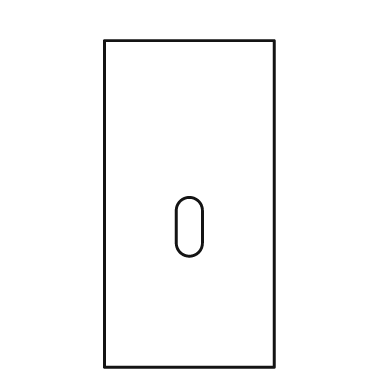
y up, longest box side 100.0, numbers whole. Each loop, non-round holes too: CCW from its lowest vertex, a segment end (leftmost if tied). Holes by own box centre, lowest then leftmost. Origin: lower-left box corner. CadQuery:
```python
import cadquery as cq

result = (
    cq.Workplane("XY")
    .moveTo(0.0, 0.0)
    .lineTo(52.0, 0.0)
    .lineTo(52.0, 100.0)
    .lineTo(0.0, 100.0)
    .close()
    .moveTo(22.0, 38.0)
    .threePointArc((26.0, 34.0), (30.0, 38.0))
    .lineTo(30.0, 48.0)
    .threePointArc((26.0, 52.0), (22.0, 48.0))
    .close()
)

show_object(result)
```